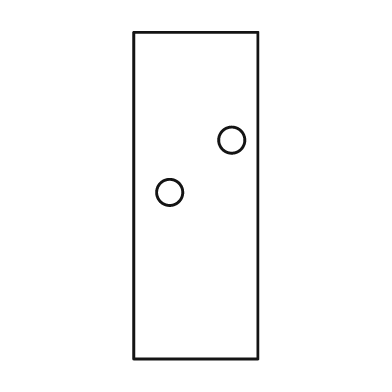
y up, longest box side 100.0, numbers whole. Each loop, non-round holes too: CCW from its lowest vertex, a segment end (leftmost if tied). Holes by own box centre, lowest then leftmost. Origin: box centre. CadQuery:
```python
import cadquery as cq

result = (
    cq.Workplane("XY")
    .moveTo(-19.0, -50.0)
    .lineTo(19.0, -50.0)
    .lineTo(19.0, 50.0)
    .lineTo(-19.0, 50.0)
    .close()
    .moveTo(-8.0, 1.0)
    .circle(4.0)
    .moveTo(11.0, 17.0)
    .circle(4.0)
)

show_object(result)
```